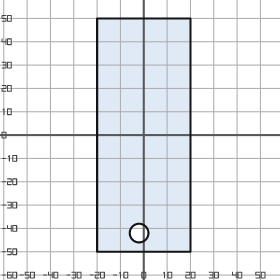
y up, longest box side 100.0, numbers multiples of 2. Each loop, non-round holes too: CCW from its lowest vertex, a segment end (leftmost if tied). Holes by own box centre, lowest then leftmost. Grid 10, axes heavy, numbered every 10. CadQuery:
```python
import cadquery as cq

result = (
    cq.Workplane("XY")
    .moveTo(-20.0, -50.0)
    .lineTo(20.0, -50.0)
    .lineTo(20.0, 50.0)
    .lineTo(-20.0, 50.0)
    .close()
    .moveTo(-2.0, -42.0)
    .circle(4.0)
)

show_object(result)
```